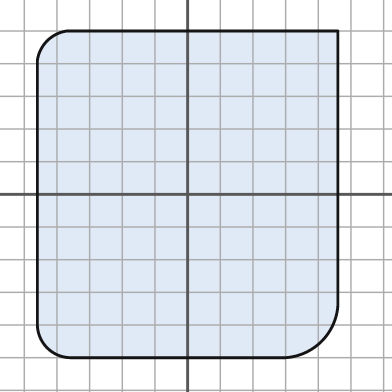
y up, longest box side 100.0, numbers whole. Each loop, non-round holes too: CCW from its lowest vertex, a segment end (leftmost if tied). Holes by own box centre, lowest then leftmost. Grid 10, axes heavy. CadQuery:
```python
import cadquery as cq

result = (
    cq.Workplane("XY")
    .moveTo(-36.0, -50.0)
    .lineTo(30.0, -50.0)
    .threePointArc((41.0, -45.0), (46.0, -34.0))
    .lineTo(46.0, 50.0)
    .lineTo(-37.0, 50.0)
    .threePointArc((-43.0, 47.0), (-46.0, 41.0))
    .lineTo(-46.0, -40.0)
    .threePointArc((-43.0, -47.0), (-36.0, -50.0))
    .close()
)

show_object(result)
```